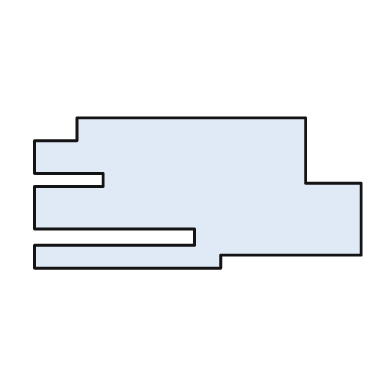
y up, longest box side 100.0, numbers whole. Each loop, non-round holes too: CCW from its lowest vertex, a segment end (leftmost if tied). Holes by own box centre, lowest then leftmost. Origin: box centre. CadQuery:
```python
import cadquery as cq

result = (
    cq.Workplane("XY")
    .moveTo(-50.0, -23.0)
    .lineTo(7.0, -23.0)
    .lineTo(7.0, -19.0)
    .lineTo(50.0, -19.0)
    .lineTo(50.0, 3.0)
    .lineTo(33.0, 3.0)
    .lineTo(33.0, 23.0)
    .lineTo(-37.0, 23.0)
    .lineTo(-37.0, 16.0)
    .lineTo(-50.0, 16.0)
    .lineTo(-50.0, 6.0)
    .lineTo(-29.0, 6.0)
    .lineTo(-29.0, 2.0)
    .lineTo(-50.0, 2.0)
    .lineTo(-50.0, -11.0)
    .lineTo(-1.0, -11.0)
    .lineTo(-1.0, -16.0)
    .lineTo(-50.0, -16.0)
    .close()
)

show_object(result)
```